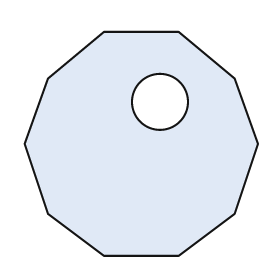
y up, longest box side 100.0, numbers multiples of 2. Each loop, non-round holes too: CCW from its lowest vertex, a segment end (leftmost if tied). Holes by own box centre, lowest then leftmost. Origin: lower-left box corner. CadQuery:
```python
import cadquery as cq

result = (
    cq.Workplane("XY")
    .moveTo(34.0, 0.0)
    .lineTo(66.0, 0.0)
    .lineTo(90.0, 18.0)
    .lineTo(100.0, 48.0)
    .lineTo(90.0, 76.0)
    .lineTo(66.0, 96.0)
    .lineTo(34.0, 96.0)
    .lineTo(10.0, 76.0)
    .lineTo(0.0, 48.0)
    .lineTo(10.0, 18.0)
    .close()
    .moveTo(58.0, 66.0)
    .circle(12.0)
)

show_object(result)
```